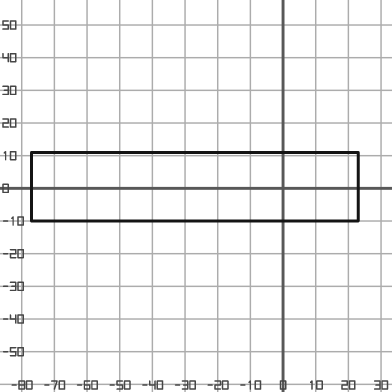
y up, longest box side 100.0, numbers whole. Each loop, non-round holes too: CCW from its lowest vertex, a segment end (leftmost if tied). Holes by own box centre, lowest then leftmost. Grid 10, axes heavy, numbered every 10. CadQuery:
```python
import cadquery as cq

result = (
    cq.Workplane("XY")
    .moveTo(-77.0, -10.0)
    .lineTo(23.0, -10.0)
    .lineTo(23.0, 11.0)
    .lineTo(-77.0, 11.0)
    .close()
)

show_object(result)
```